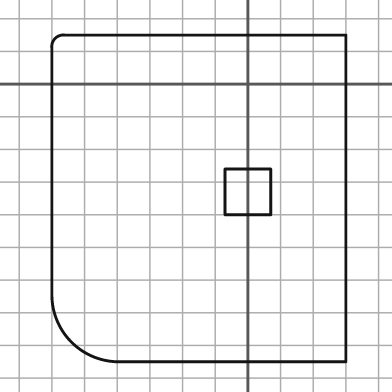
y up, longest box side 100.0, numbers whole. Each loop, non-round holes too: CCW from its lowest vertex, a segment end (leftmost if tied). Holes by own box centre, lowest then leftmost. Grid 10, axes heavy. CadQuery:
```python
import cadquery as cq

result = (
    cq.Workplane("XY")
    .moveTo(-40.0, -85.0)
    .lineTo(30.0, -85.0)
    .lineTo(30.0, 15.0)
    .lineTo(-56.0, 15.0)
    .threePointArc((-59.0, 14.0), (-60.0, 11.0))
    .lineTo(-60.0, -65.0)
    .threePointArc((-54.0, -79.0), (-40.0, -85.0))
    .close()
    .moveTo(-7.0, -40.0)
    .lineTo(7.0, -40.0)
    .lineTo(7.0, -26.0)
    .lineTo(-7.0, -26.0)
    .close()
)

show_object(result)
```